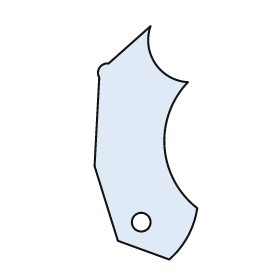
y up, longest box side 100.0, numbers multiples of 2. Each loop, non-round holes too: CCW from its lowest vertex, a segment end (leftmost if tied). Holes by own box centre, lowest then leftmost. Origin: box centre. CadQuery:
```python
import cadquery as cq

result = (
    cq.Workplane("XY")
    .moveTo(10.0, -50.0)
    .threePointArc((18.0, -40.0), (22.0, -28.0))
    .threePointArc((8.0, -2.0), (18.0, 26.0))
    .threePointArc((4.0, 34.0), (2.0, 50.0))
    .lineTo(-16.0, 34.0)
    .threePointArc((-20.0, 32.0), (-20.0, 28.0))
    .lineTo(-22.0, -10.0)
    .lineTo(-12.0, -42.0)
    .close()
    .moveTo(-2.0, -34.0)
    .circle(4.0)
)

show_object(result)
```